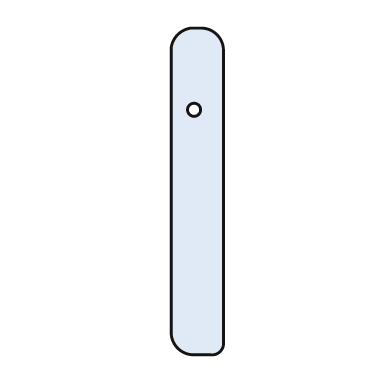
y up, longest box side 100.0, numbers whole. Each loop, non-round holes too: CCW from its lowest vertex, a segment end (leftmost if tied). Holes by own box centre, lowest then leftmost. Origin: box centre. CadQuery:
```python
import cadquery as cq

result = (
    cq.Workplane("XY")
    .moveTo(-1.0, -50.0)
    .lineTo(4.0, -50.0)
    .threePointArc((7.0, -49.0), (8.0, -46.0))
    .lineTo(8.0, 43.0)
    .threePointArc((6.0, 48.0), (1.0, 50.0))
    .lineTo(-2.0, 50.0)
    .threePointArc((-6.0, 48.0), (-8.0, 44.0))
    .lineTo(-8.0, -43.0)
    .threePointArc((-6.0, -48.0), (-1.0, -50.0))
    .close()
    .moveTo(-1.0, 25.0)
    .circle(2.0)
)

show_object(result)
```